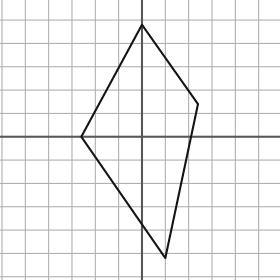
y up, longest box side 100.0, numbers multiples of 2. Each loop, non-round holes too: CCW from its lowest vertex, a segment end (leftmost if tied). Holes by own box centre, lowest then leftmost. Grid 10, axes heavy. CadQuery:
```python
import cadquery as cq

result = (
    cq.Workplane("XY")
    .moveTo(10.0, -52.0)
    .lineTo(24.0, 14.0)
    .lineTo(0.0, 48.0)
    .lineTo(-26.0, 0.0)
    .close()
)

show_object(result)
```